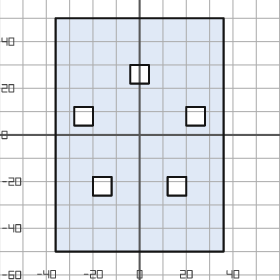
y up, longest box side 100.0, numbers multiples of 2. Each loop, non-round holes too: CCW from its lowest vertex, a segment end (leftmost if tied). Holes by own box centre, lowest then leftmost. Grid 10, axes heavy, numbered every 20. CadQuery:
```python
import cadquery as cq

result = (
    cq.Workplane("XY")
    .moveTo(-36.0, -50.0)
    .lineTo(36.0, -50.0)
    .lineTo(36.0, 50.0)
    .lineTo(-36.0, 50.0)
    .close()
    .moveTo(-20.0, -26.0)
    .lineTo(-12.0, -26.0)
    .lineTo(-12.0, -18.0)
    .lineTo(-20.0, -18.0)
    .close()
    .moveTo(12.0, -26.0)
    .lineTo(20.0, -26.0)
    .lineTo(20.0, -18.0)
    .lineTo(12.0, -18.0)
    .close()
    .moveTo(-28.0, 4.0)
    .lineTo(-20.0, 4.0)
    .lineTo(-20.0, 12.0)
    .lineTo(-28.0, 12.0)
    .close()
    .moveTo(20.0, 4.0)
    .lineTo(28.0, 4.0)
    .lineTo(28.0, 12.0)
    .lineTo(20.0, 12.0)
    .close()
    .moveTo(-4.0, 22.0)
    .lineTo(4.0, 22.0)
    .lineTo(4.0, 30.0)
    .lineTo(-4.0, 30.0)
    .close()
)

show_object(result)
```